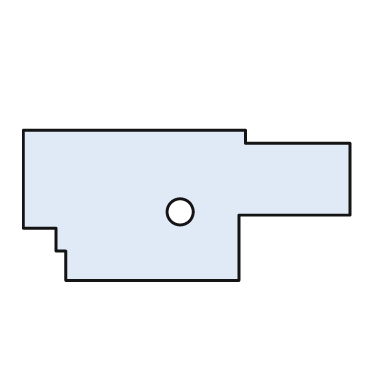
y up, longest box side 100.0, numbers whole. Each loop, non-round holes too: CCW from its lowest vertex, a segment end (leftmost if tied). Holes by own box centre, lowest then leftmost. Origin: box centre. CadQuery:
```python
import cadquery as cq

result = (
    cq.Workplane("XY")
    .moveTo(-37.0, -23.0)
    .lineTo(16.0, -23.0)
    .lineTo(16.0, -3.0)
    .lineTo(50.0, -3.0)
    .lineTo(50.0, 19.0)
    .lineTo(18.0, 19.0)
    .lineTo(18.0, 23.0)
    .lineTo(-50.0, 23.0)
    .lineTo(-50.0, -7.0)
    .lineTo(-40.0, -7.0)
    .lineTo(-40.0, -14.0)
    .lineTo(-37.0, -14.0)
    .close()
    .moveTo(-2.0, -2.0)
    .circle(4.0)
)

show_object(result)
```